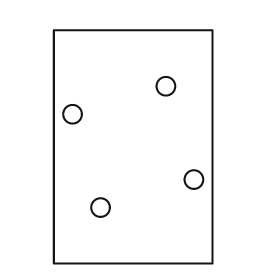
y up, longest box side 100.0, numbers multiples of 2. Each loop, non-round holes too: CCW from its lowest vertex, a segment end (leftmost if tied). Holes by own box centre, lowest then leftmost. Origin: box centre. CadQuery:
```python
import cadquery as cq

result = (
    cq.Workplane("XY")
    .moveTo(-34.0, -50.0)
    .lineTo(34.0, -50.0)
    .lineTo(34.0, 50.0)
    .lineTo(-34.0, 50.0)
    .close()
    .moveTo(-14.0, -26.0)
    .circle(4.0)
    .moveTo(26.0, -14.0)
    .circle(4.0)
    .moveTo(-26.0, 14.0)
    .circle(4.0)
    .moveTo(14.0, 26.0)
    .circle(4.0)
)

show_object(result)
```